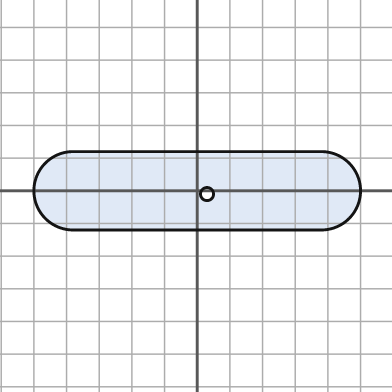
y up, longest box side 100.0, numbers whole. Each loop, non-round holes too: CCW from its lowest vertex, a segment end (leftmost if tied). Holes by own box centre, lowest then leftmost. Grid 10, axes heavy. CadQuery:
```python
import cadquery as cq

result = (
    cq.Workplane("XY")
    .moveTo(-38.0, -12.0)
    .lineTo(38.0, -12.0)
    .threePointArc((50.0, 0.0), (38.0, 12.0))
    .lineTo(-38.0, 12.0)
    .threePointArc((-50.0, 0.0), (-38.0, -12.0))
    .close()
    .moveTo(3.0, -1.0)
    .circle(2.0)
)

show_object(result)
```